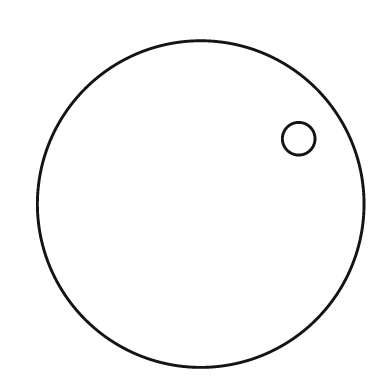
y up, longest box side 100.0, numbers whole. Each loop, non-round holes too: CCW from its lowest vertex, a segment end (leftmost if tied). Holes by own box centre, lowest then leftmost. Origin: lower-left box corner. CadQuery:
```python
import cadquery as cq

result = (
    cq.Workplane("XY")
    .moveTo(50.0, 50.0)
    .circle(50.0)
    .moveTo(80.0, 70.0)
    .circle(5.0)
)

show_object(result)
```